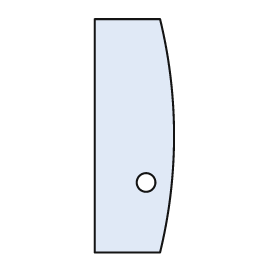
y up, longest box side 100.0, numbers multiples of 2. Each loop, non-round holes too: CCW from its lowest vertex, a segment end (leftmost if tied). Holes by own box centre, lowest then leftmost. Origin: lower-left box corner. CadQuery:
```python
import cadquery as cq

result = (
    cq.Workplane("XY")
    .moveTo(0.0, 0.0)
    .lineTo(28.0, 0.0)
    .threePointArc((34.0, 50.0), (28.0, 100.0))
    .lineTo(0.0, 100.0)
    .close()
    .moveTo(22.0, 30.0)
    .circle(4.0)
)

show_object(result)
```